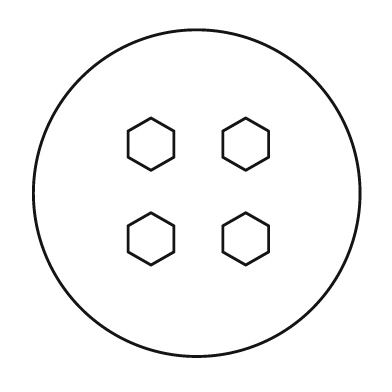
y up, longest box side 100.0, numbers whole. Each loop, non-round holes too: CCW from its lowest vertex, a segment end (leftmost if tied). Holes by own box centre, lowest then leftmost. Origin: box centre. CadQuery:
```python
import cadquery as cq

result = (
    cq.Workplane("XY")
    .moveTo(0.0, 0.0)
    .circle(50.0)
    .moveTo(-14.0, -22.0)
    .lineTo(-7.0, -18.0)
    .lineTo(-7.0, -10.0)
    .lineTo(-14.0, -6.0)
    .lineTo(-21.0, -10.0)
    .lineTo(-21.0, -18.0)
    .close()
    .moveTo(15.0, -22.0)
    .lineTo(22.0, -18.0)
    .lineTo(22.0, -10.0)
    .lineTo(15.0, -6.0)
    .lineTo(8.0, -10.0)
    .lineTo(8.0, -18.0)
    .close()
    .moveTo(-14.0, 7.0)
    .lineTo(-7.0, 11.0)
    .lineTo(-7.0, 19.0)
    .lineTo(-14.0, 23.0)
    .lineTo(-21.0, 19.0)
    .lineTo(-21.0, 11.0)
    .close()
    .moveTo(15.0, 7.0)
    .lineTo(22.0, 11.0)
    .lineTo(22.0, 19.0)
    .lineTo(15.0, 23.0)
    .lineTo(8.0, 19.0)
    .lineTo(8.0, 11.0)
    .close()
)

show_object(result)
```